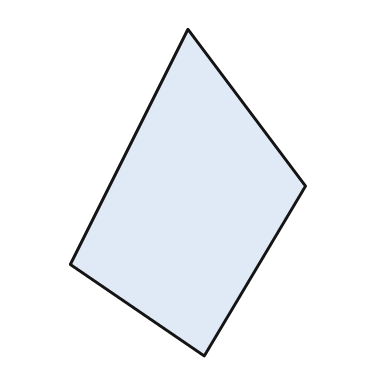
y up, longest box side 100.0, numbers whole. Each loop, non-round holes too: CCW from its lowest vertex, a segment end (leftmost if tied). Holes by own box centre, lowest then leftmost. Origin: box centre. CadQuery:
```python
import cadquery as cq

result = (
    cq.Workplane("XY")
    .moveTo(5.0, -50.0)
    .lineTo(36.0, 2.0)
    .lineTo(0.0, 50.0)
    .lineTo(-36.0, -22.0)
    .close()
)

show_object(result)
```